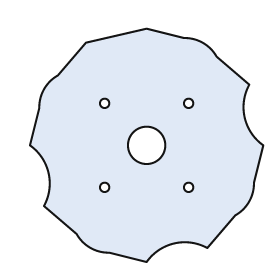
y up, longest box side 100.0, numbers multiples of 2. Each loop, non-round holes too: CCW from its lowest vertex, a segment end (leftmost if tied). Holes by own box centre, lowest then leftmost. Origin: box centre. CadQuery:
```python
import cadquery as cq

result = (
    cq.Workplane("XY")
    .moveTo(0.0, -50.0)
    .threePointArc((12.0, -42.0), (26.0, -44.0))
    .lineTo(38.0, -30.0)
    .threePointArc((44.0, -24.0), (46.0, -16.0))
    .lineTo(50.0, 0.0)
    .threePointArc((42.0, 12.0), (44.0, 26.0))
    .lineTo(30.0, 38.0)
    .threePointArc((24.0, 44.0), (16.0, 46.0))
    .lineTo(0.0, 50.0)
    .lineTo(-26.0, 44.0)
    .lineTo(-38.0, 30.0)
    .threePointArc((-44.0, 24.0), (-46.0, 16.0))
    .lineTo(-50.0, 0.0)
    .threePointArc((-42.0, -12.0), (-44.0, -26.0))
    .lineTo(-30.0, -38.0)
    .threePointArc((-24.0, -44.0), (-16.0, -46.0))
    .close()
    .moveTo(-18.0, -18.0)
    .circle(2.0)
    .moveTo(18.0, -18.0)
    .circle(2.0)
    .moveTo(0.0, 0.0)
    .circle(8.0)
    .moveTo(-18.0, 18.0)
    .circle(2.0)
    .moveTo(18.0, 18.0)
    .circle(2.0)
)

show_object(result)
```